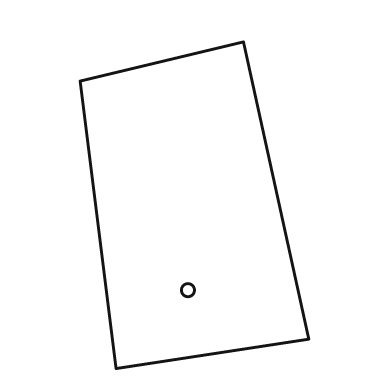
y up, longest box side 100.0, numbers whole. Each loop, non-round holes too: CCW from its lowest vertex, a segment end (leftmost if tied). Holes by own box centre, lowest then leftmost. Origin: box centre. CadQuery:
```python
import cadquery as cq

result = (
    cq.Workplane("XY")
    .moveTo(-24.0, -50.0)
    .lineTo(35.0, -41.0)
    .lineTo(15.0, 50.0)
    .lineTo(-35.0, 38.0)
    .close()
    .moveTo(-2.0, -26.0)
    .circle(2.0)
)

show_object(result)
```